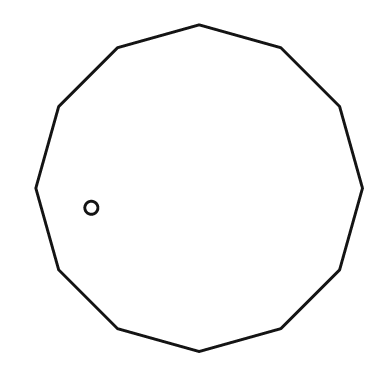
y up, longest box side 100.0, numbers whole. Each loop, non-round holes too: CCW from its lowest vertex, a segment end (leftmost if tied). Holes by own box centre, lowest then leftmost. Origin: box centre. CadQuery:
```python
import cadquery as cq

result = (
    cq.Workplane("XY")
    .moveTo(0.0, -50.0)
    .lineTo(25.0, -43.0)
    .lineTo(43.0, -25.0)
    .lineTo(50.0, 0.0)
    .lineTo(43.0, 25.0)
    .lineTo(25.0, 43.0)
    .lineTo(0.0, 50.0)
    .lineTo(-25.0, 43.0)
    .lineTo(-43.0, 25.0)
    .lineTo(-50.0, 0.0)
    .lineTo(-43.0, -25.0)
    .lineTo(-25.0, -43.0)
    .close()
    .moveTo(-33.0, -6.0)
    .circle(2.0)
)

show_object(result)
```